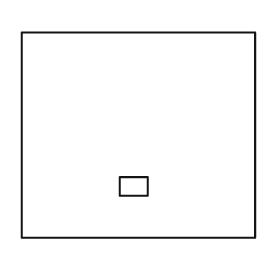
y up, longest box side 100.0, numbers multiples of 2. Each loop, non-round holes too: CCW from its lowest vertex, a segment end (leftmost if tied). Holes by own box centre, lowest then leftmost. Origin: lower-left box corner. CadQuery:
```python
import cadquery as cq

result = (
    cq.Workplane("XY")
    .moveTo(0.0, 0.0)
    .lineTo(100.0, 0.0)
    .lineTo(100.0, 88.0)
    .lineTo(0.0, 88.0)
    .close()
    .moveTo(42.0, 18.0)
    .lineTo(54.0, 18.0)
    .lineTo(54.0, 26.0)
    .lineTo(42.0, 26.0)
    .close()
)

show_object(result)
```